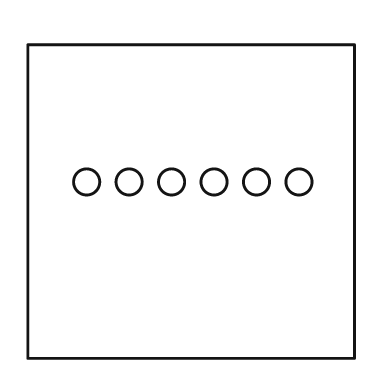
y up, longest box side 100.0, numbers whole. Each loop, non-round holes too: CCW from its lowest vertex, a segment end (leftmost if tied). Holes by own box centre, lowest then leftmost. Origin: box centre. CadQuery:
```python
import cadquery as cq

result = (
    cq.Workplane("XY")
    .moveTo(-50.0, -48.0)
    .lineTo(50.0, -48.0)
    .lineTo(50.0, 48.0)
    .lineTo(-50.0, 48.0)
    .close()
    .moveTo(-32.0, 6.0)
    .circle(4.0)
    .moveTo(-19.0, 6.0)
    .circle(4.0)
    .moveTo(-6.0, 6.0)
    .circle(4.0)
    .moveTo(7.0, 6.0)
    .circle(4.0)
    .moveTo(20.0, 6.0)
    .circle(4.0)
    .moveTo(33.0, 6.0)
    .circle(4.0)
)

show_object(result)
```